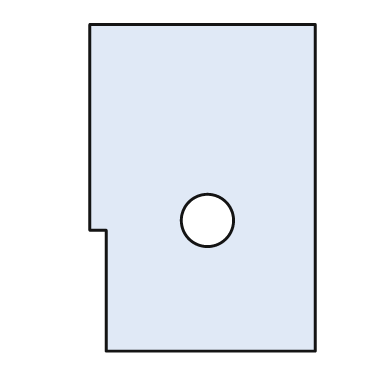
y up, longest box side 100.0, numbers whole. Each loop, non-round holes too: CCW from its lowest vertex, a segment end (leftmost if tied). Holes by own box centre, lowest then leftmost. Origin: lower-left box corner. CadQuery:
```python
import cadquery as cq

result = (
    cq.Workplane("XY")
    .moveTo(5.0, 0.0)
    .lineTo(69.0, 0.0)
    .lineTo(69.0, 100.0)
    .lineTo(0.0, 100.0)
    .lineTo(0.0, 37.0)
    .lineTo(5.0, 37.0)
    .close()
    .moveTo(36.0, 40.0)
    .circle(8.0)
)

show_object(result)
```